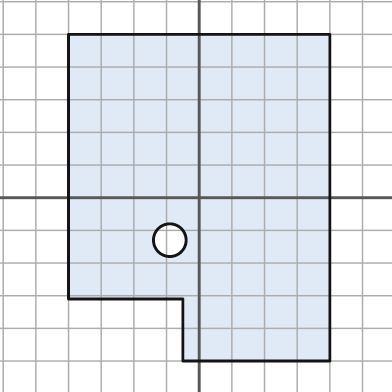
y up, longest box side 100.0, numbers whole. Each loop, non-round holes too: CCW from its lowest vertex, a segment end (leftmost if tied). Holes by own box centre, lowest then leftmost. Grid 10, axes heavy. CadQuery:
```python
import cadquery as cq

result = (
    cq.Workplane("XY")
    .moveTo(-5.0, -50.0)
    .lineTo(40.0, -50.0)
    .lineTo(40.0, 50.0)
    .lineTo(-40.0, 50.0)
    .lineTo(-40.0, -31.0)
    .lineTo(-5.0, -31.0)
    .close()
    .moveTo(-9.0, -13.0)
    .circle(5.0)
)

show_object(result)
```